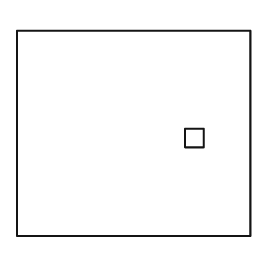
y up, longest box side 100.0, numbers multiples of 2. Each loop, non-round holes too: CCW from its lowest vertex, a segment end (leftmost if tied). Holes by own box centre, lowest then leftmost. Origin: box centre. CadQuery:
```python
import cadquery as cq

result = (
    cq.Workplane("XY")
    .moveTo(-50.0, -44.0)
    .lineTo(50.0, -44.0)
    .lineTo(50.0, 44.0)
    .lineTo(-50.0, 44.0)
    .close()
    .moveTo(22.0, -6.0)
    .lineTo(30.0, -6.0)
    .lineTo(30.0, 2.0)
    .lineTo(22.0, 2.0)
    .close()
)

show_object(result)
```